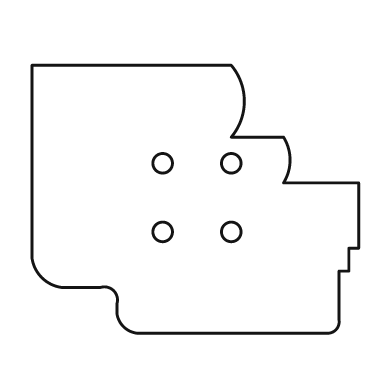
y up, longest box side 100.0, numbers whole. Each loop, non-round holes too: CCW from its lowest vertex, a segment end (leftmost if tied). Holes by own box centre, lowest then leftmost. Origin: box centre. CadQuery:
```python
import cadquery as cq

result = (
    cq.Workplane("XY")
    .moveTo(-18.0, -41.0)
    .lineTo(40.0, -41.0)
    .threePointArc((43.0, -40.0), (44.0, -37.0))
    .lineTo(44.0, -22.0)
    .lineTo(47.0, -22.0)
    .lineTo(47.0, -15.0)
    .lineTo(50.0, -15.0)
    .lineTo(50.0, 5.0)
    .lineTo(27.0, 5.0)
    .threePointArc((29.0, 12.0), (27.0, 19.0))
    .lineTo(11.0, 19.0)
    .threePointArc((15.0, 30.0), (11.0, 41.0))
    .lineTo(-50.0, 41.0)
    .lineTo(-50.0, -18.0)
    .threePointArc((-47.0, -24.0), (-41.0, -27.0))
    .lineTo(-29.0, -27.0)
    .threePointArc((-25.0, -28.0), (-24.0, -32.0))
    .lineTo(-24.0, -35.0)
    .threePointArc((-22.0, -39.0), (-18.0, -41.0))
    .close()
    .moveTo(-10.0, -10.0)
    .circle(3.0)
    .moveTo(11.0, -10.0)
    .circle(3.0)
    .moveTo(-10.0, 11.0)
    .circle(3.0)
    .moveTo(11.0, 11.0)
    .circle(3.0)
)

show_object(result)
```